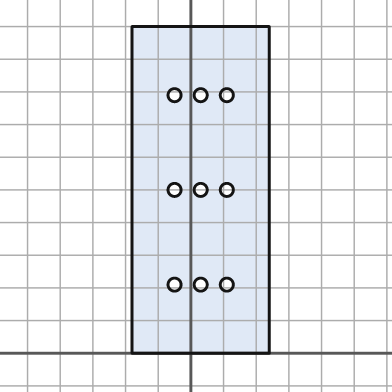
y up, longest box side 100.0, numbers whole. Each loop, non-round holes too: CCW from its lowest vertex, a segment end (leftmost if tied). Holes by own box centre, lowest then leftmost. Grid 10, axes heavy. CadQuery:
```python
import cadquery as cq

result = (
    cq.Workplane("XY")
    .moveTo(-18.0, 0.0)
    .lineTo(24.0, 0.0)
    .lineTo(24.0, 100.0)
    .lineTo(-18.0, 100.0)
    .close()
    .moveTo(-5.0, 21.0)
    .circle(2.0)
    .moveTo(3.0, 21.0)
    .circle(2.0)
    .moveTo(11.0, 21.0)
    .circle(2.0)
    .moveTo(-5.0, 50.0)
    .circle(2.0)
    .moveTo(3.0, 50.0)
    .circle(2.0)
    .moveTo(11.0, 50.0)
    .circle(2.0)
    .moveTo(-5.0, 79.0)
    .circle(2.0)
    .moveTo(3.0, 79.0)
    .circle(2.0)
    .moveTo(11.0, 79.0)
    .circle(2.0)
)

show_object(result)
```